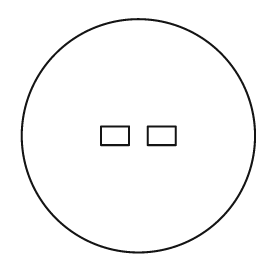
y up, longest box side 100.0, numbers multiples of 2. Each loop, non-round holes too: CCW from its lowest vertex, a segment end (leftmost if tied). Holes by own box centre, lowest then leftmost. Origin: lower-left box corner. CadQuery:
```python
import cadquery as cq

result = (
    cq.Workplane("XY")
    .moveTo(50.0, 50.0)
    .circle(50.0)
    .moveTo(34.0, 46.0)
    .lineTo(46.0, 46.0)
    .lineTo(46.0, 54.0)
    .lineTo(34.0, 54.0)
    .close()
    .moveTo(54.0, 46.0)
    .lineTo(66.0, 46.0)
    .lineTo(66.0, 54.0)
    .lineTo(54.0, 54.0)
    .close()
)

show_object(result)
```